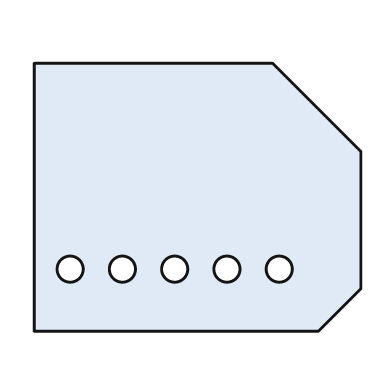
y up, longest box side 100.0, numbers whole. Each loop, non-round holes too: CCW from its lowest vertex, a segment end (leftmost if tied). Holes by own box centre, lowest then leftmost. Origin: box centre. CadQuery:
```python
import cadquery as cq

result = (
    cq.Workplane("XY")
    .moveTo(-50.0, -41.0)
    .lineTo(37.0, -41.0)
    .lineTo(50.0, -28.0)
    .lineTo(50.0, 14.0)
    .lineTo(23.0, 41.0)
    .lineTo(-50.0, 41.0)
    .close()
    .moveTo(-39.0, -22.0)
    .circle(4.0)
    .moveTo(-23.0, -22.0)
    .circle(4.0)
    .moveTo(-7.0, -22.0)
    .circle(4.0)
    .moveTo(9.0, -22.0)
    .circle(4.0)
    .moveTo(25.0, -22.0)
    .circle(4.0)
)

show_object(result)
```